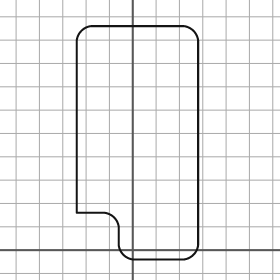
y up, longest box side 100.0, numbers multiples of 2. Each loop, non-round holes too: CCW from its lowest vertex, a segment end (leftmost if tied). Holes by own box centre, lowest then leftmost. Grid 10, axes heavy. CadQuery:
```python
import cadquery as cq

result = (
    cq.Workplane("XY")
    .moveTo(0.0, -4.0)
    .lineTo(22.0, -4.0)
    .threePointArc((26.0, -2.0), (28.0, 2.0))
    .lineTo(28.0, 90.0)
    .threePointArc((26.0, 94.0), (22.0, 96.0))
    .lineTo(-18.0, 96.0)
    .threePointArc((-22.0, 94.0), (-24.0, 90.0))
    .lineTo(-24.0, 16.0)
    .lineTo(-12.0, 16.0)
    .threePointArc((-8.0, 14.0), (-6.0, 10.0))
    .lineTo(-6.0, 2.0)
    .threePointArc((-4.0, -2.0), (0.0, -4.0))
    .close()
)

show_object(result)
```